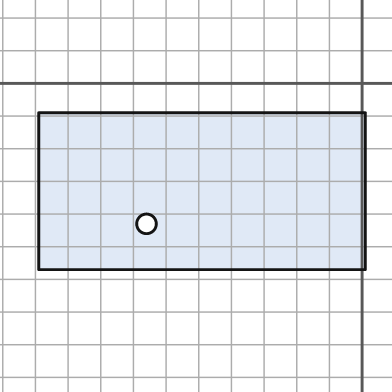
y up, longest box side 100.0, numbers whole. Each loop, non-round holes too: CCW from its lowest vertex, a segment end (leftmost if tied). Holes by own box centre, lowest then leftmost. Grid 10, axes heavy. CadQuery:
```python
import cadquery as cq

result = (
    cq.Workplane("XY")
    .moveTo(-99.0, -57.0)
    .lineTo(1.0, -57.0)
    .lineTo(1.0, -9.0)
    .lineTo(-99.0, -9.0)
    .close()
    .moveTo(-66.0, -43.0)
    .circle(3.0)
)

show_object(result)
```